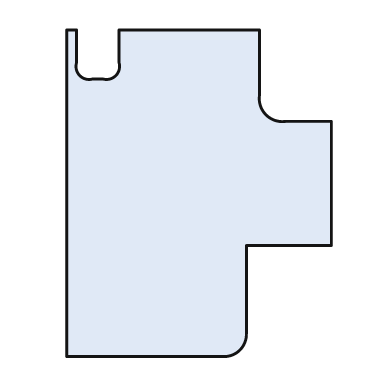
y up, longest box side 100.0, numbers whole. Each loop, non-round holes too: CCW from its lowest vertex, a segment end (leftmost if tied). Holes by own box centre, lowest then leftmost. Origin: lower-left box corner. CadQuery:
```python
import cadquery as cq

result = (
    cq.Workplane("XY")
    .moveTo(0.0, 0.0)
    .lineTo(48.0, 0.0)
    .threePointArc((53.0, 2.0), (55.0, 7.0))
    .lineTo(55.0, 34.0)
    .lineTo(81.0, 34.0)
    .lineTo(81.0, 72.0)
    .lineTo(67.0, 72.0)
    .threePointArc((61.0, 74.0), (59.0, 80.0))
    .lineTo(59.0, 100.0)
    .lineTo(16.0, 100.0)
    .lineTo(16.0, 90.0)
    .threePointArc((15.0, 86.0), (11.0, 85.0))
    .lineTo(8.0, 85.0)
    .threePointArc((4.0, 86.0), (3.0, 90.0))
    .lineTo(3.0, 100.0)
    .lineTo(0.0, 100.0)
    .close()
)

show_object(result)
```